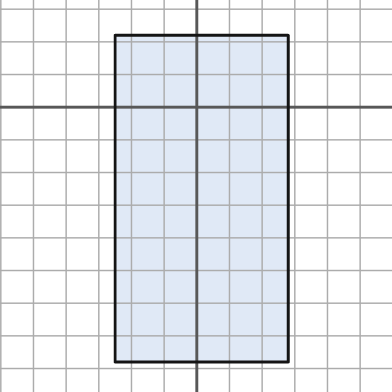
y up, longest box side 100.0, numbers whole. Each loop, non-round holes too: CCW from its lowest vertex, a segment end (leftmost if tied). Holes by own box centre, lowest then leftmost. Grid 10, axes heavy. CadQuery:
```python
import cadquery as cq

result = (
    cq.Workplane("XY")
    .moveTo(-25.0, -78.0)
    .lineTo(28.0, -78.0)
    .lineTo(28.0, 22.0)
    .lineTo(-25.0, 22.0)
    .close()
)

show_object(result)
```